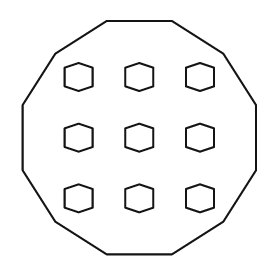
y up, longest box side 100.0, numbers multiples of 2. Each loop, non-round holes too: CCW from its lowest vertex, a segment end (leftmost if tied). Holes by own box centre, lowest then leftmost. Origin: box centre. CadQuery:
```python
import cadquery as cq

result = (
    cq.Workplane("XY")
    .moveTo(-14.0, -50.0)
    .lineTo(14.0, -50.0)
    .lineTo(36.0, -36.0)
    .lineTo(50.0, -14.0)
    .lineTo(50.0, 14.0)
    .lineTo(36.0, 36.0)
    .lineTo(14.0, 50.0)
    .lineTo(-14.0, 50.0)
    .lineTo(-36.0, 36.0)
    .lineTo(-50.0, 14.0)
    .lineTo(-50.0, -14.0)
    .lineTo(-36.0, -36.0)
    .close()
    .moveTo(-26.0, -32.0)
    .lineTo(-20.0, -30.0)
    .lineTo(-20.0, -22.0)
    .lineTo(-26.0, -20.0)
    .lineTo(-32.0, -22.0)
    .lineTo(-32.0, -30.0)
    .close()
    .moveTo(0.0, -32.0)
    .lineTo(6.0, -30.0)
    .lineTo(6.0, -22.0)
    .lineTo(0.0, -20.0)
    .lineTo(-6.0, -22.0)
    .lineTo(-6.0, -30.0)
    .close()
    .moveTo(26.0, -32.0)
    .lineTo(32.0, -30.0)
    .lineTo(32.0, -22.0)
    .lineTo(26.0, -20.0)
    .lineTo(20.0, -22.0)
    .lineTo(20.0, -30.0)
    .close()
    .moveTo(-26.0, -6.0)
    .lineTo(-20.0, -4.0)
    .lineTo(-20.0, 4.0)
    .lineTo(-26.0, 6.0)
    .lineTo(-32.0, 4.0)
    .lineTo(-32.0, -4.0)
    .close()
    .moveTo(0.0, -6.0)
    .lineTo(6.0, -4.0)
    .lineTo(6.0, 4.0)
    .lineTo(0.0, 6.0)
    .lineTo(-6.0, 4.0)
    .lineTo(-6.0, -4.0)
    .close()
    .moveTo(26.0, -6.0)
    .lineTo(32.0, -4.0)
    .lineTo(32.0, 4.0)
    .lineTo(26.0, 6.0)
    .lineTo(20.0, 4.0)
    .lineTo(20.0, -4.0)
    .close()
    .moveTo(-26.0, 20.0)
    .lineTo(-20.0, 22.0)
    .lineTo(-20.0, 30.0)
    .lineTo(-26.0, 32.0)
    .lineTo(-32.0, 30.0)
    .lineTo(-32.0, 22.0)
    .close()
    .moveTo(0.0, 20.0)
    .lineTo(6.0, 22.0)
    .lineTo(6.0, 30.0)
    .lineTo(0.0, 32.0)
    .lineTo(-6.0, 30.0)
    .lineTo(-6.0, 22.0)
    .close()
    .moveTo(26.0, 20.0)
    .lineTo(32.0, 22.0)
    .lineTo(32.0, 30.0)
    .lineTo(26.0, 32.0)
    .lineTo(20.0, 30.0)
    .lineTo(20.0, 22.0)
    .close()
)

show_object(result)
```